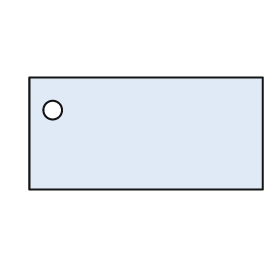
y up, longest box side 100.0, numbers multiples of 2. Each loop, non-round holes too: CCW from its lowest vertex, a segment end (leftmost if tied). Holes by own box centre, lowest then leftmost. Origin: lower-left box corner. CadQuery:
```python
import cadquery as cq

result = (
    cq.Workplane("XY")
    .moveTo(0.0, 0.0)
    .lineTo(100.0, 0.0)
    .lineTo(100.0, 48.0)
    .lineTo(0.0, 48.0)
    .close()
    .moveTo(10.0, 34.0)
    .circle(4.0)
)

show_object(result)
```